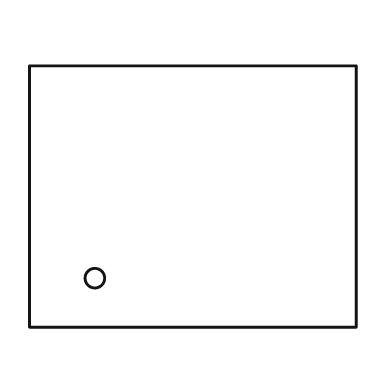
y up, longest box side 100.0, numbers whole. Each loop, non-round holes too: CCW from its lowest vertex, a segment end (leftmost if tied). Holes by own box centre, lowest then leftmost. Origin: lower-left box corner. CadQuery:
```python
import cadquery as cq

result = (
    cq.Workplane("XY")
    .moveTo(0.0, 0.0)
    .lineTo(100.0, 0.0)
    .lineTo(100.0, 80.0)
    .lineTo(0.0, 80.0)
    .close()
    .moveTo(20.0, 15.0)
    .circle(3.0)
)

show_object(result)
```